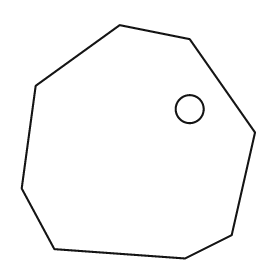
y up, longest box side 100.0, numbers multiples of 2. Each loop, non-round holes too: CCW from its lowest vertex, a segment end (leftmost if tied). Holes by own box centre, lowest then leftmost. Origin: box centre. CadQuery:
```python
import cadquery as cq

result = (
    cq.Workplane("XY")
    .moveTo(20.0, -50.0)
    .lineTo(40.0, -40.0)
    .lineTo(50.0, 4.0)
    .lineTo(22.0, 44.0)
    .lineTo(-8.0, 50.0)
    .lineTo(-44.0, 24.0)
    .lineTo(-50.0, -20.0)
    .lineTo(-36.0, -46.0)
    .close()
    .moveTo(22.0, 14.0)
    .circle(6.0)
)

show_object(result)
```